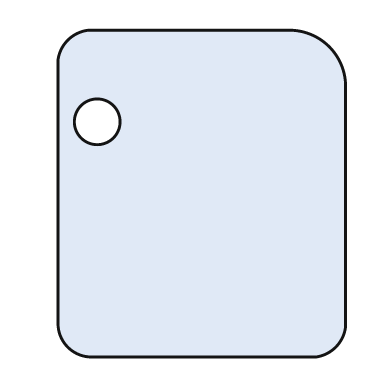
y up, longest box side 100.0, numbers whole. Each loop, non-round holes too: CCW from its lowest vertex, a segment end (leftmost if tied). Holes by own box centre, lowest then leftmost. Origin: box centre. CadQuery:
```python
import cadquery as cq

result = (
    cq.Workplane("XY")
    .moveTo(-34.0, -50.0)
    .lineTo(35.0, -50.0)
    .threePointArc((41.0, -47.0), (44.0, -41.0))
    .lineTo(44.0, 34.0)
    .threePointArc((39.0, 45.0), (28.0, 50.0))
    .lineTo(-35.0, 50.0)
    .threePointArc((-41.0, 47.0), (-44.0, 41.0))
    .lineTo(-44.0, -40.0)
    .threePointArc((-41.0, -47.0), (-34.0, -50.0))
    .close()
    .moveTo(-32.0, 22.0)
    .circle(7.0)
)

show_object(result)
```